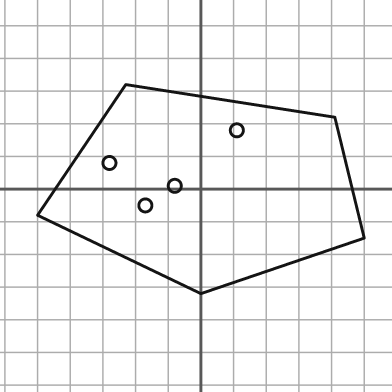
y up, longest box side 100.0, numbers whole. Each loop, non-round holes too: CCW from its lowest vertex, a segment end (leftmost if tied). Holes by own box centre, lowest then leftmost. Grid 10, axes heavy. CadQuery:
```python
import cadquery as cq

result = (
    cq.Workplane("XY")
    .moveTo(0.0, -32.0)
    .lineTo(50.0, -15.0)
    .lineTo(41.0, 22.0)
    .lineTo(-23.0, 32.0)
    .lineTo(-50.0, -8.0)
    .close()
    .moveTo(-17.0, -5.0)
    .circle(2.0)
    .moveTo(-8.0, 1.0)
    .circle(2.0)
    .moveTo(-28.0, 8.0)
    .circle(2.0)
    .moveTo(11.0, 18.0)
    .circle(2.0)
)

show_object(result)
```